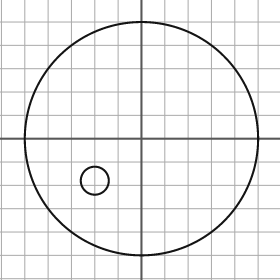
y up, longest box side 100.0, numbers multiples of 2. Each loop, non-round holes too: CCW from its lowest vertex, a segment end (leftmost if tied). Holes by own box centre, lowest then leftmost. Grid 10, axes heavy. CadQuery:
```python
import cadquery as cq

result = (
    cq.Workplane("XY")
    .moveTo(0.0, 0.0)
    .circle(50.0)
    .moveTo(-20.0, -18.0)
    .circle(6.0)
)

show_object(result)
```